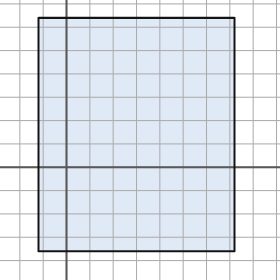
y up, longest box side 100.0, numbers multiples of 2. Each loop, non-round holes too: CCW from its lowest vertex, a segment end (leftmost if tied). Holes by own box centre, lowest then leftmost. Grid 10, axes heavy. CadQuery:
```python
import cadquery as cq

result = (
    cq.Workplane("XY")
    .moveTo(-12.0, -36.0)
    .lineTo(72.0, -36.0)
    .lineTo(72.0, 64.0)
    .lineTo(-12.0, 64.0)
    .close()
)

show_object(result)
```